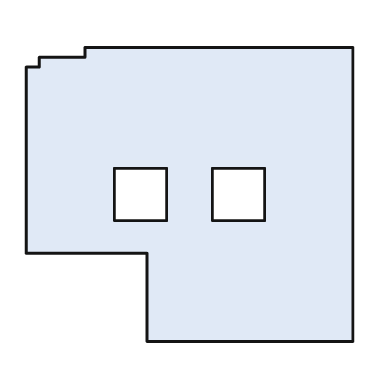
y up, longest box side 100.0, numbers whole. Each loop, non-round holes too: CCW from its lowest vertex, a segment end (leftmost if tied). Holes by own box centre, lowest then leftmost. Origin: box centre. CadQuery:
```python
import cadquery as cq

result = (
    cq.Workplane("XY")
    .moveTo(-13.0, -45.0)
    .lineTo(50.0, -45.0)
    .lineTo(50.0, 45.0)
    .lineTo(-32.0, 45.0)
    .lineTo(-32.0, 42.0)
    .lineTo(-46.0, 42.0)
    .lineTo(-46.0, 39.0)
    .lineTo(-50.0, 39.0)
    .lineTo(-50.0, -18.0)
    .lineTo(-13.0, -18.0)
    .close()
    .moveTo(-23.0, -8.0)
    .lineTo(-7.0, -8.0)
    .lineTo(-7.0, 8.0)
    .lineTo(-23.0, 8.0)
    .close()
    .moveTo(7.0, -8.0)
    .lineTo(23.0, -8.0)
    .lineTo(23.0, 8.0)
    .lineTo(7.0, 8.0)
    .close()
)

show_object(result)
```